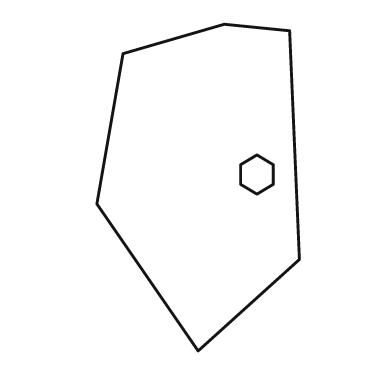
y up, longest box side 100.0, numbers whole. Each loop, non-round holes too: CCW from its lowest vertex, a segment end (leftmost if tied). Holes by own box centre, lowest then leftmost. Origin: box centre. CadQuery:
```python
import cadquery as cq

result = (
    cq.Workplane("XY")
    .moveTo(0.0, -50.0)
    .lineTo(31.0, -22.0)
    .lineTo(28.0, 48.0)
    .lineTo(8.0, 50.0)
    .lineTo(-23.0, 41.0)
    .lineTo(-31.0, -5.0)
    .close()
    .moveTo(18.0, -2.0)
    .lineTo(23.0, 1.0)
    .lineTo(23.0, 7.0)
    .lineTo(18.0, 10.0)
    .lineTo(13.0, 7.0)
    .lineTo(13.0, 1.0)
    .close()
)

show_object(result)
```